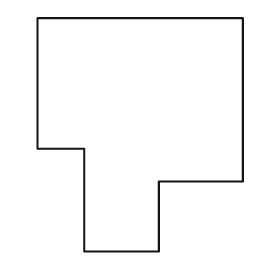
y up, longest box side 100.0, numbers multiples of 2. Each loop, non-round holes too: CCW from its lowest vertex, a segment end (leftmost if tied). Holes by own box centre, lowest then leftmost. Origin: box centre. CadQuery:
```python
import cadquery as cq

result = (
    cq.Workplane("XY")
    .moveTo(-24.0, -50.0)
    .lineTo(8.0, -50.0)
    .lineTo(8.0, -20.0)
    .lineTo(44.0, -20.0)
    .lineTo(44.0, 50.0)
    .lineTo(-44.0, 50.0)
    .lineTo(-44.0, -6.0)
    .lineTo(-24.0, -6.0)
    .close()
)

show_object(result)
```